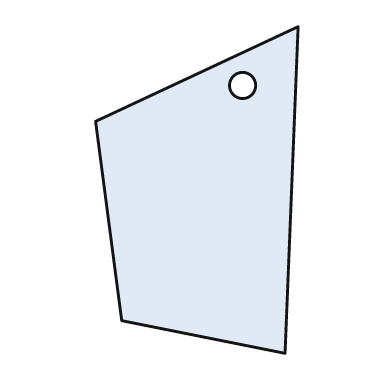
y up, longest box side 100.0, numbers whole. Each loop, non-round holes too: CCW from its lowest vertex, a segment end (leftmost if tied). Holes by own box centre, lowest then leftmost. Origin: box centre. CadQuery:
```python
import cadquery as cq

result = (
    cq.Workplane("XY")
    .moveTo(27.0, -50.0)
    .lineTo(31.0, 50.0)
    .lineTo(-31.0, 21.0)
    .lineTo(-23.0, -40.0)
    .close()
    .moveTo(14.0, 32.0)
    .circle(4.0)
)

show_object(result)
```